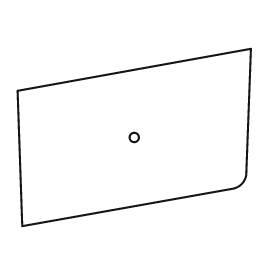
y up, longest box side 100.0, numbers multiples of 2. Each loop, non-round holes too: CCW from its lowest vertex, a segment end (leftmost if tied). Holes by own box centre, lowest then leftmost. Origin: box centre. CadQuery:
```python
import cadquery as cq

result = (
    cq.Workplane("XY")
    .moveTo(-48.0, -38.0)
    .lineTo(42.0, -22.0)
    .threePointArc((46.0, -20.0), (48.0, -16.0))
    .lineTo(50.0, 38.0)
    .lineTo(-50.0, 20.0)
    .close()
    .moveTo(0.0, 0.0)
    .circle(2.0)
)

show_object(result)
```